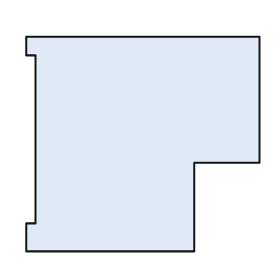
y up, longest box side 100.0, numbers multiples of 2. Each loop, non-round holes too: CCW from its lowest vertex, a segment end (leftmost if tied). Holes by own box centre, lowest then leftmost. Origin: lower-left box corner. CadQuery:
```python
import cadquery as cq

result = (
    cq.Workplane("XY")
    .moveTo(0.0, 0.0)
    .lineTo(72.0, 0.0)
    .lineTo(72.0, 38.0)
    .lineTo(100.0, 38.0)
    .lineTo(100.0, 92.0)
    .lineTo(0.0, 92.0)
    .lineTo(0.0, 84.0)
    .lineTo(4.0, 84.0)
    .lineTo(4.0, 12.0)
    .lineTo(0.0, 12.0)
    .close()
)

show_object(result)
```